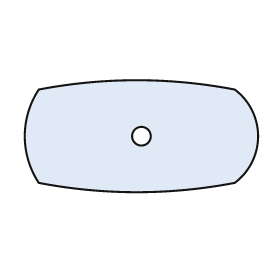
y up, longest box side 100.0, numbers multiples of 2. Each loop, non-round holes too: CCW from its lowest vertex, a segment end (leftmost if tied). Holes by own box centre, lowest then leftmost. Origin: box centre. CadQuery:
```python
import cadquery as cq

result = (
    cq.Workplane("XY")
    .moveTo(-44.0, -20.0)
    .threePointArc((-2.0, -24.0), (40.0, -20.0))
    .threePointArc((50.0, 0.0), (40.0, 20.0))
    .threePointArc((-2.0, 24.0), (-44.0, 20.0))
    .threePointArc((-50.0, 0.0), (-44.0, -20.0))
    .close()
    .moveTo(0.0, 0.0)
    .circle(4.0)
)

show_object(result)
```